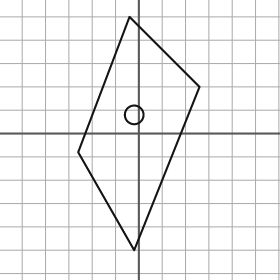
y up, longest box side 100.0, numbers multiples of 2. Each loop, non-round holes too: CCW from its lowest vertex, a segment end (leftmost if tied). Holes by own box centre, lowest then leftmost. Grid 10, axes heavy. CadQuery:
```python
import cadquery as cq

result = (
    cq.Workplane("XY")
    .moveTo(-2.0, -50.0)
    .lineTo(26.0, 20.0)
    .lineTo(-4.0, 50.0)
    .lineTo(-26.0, -8.0)
    .close()
    .moveTo(-2.0, 8.0)
    .circle(4.0)
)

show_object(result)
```